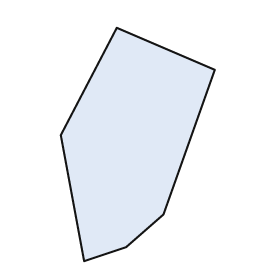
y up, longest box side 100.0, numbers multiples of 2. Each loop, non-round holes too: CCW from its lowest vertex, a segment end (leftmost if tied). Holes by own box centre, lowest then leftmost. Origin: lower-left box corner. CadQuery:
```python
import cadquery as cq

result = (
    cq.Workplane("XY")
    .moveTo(10.0, 0.0)
    .lineTo(28.0, 6.0)
    .lineTo(44.0, 20.0)
    .lineTo(66.0, 82.0)
    .lineTo(24.0, 100.0)
    .lineTo(0.0, 54.0)
    .close()
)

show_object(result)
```